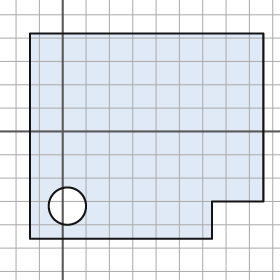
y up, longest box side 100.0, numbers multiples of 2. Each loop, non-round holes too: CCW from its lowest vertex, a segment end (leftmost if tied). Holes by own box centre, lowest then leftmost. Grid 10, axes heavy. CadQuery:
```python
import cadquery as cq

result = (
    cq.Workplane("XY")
    .moveTo(-14.0, -46.0)
    .lineTo(64.0, -46.0)
    .lineTo(64.0, -30.0)
    .lineTo(86.0, -30.0)
    .lineTo(86.0, 42.0)
    .lineTo(-14.0, 42.0)
    .close()
    .moveTo(2.0, -32.0)
    .circle(8.0)
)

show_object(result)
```